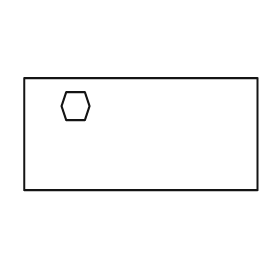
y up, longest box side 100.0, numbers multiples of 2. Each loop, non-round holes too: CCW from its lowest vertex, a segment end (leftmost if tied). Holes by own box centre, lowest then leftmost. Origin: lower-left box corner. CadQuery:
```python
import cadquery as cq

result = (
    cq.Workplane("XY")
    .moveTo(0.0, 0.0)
    .lineTo(100.0, 0.0)
    .lineTo(100.0, 48.0)
    .lineTo(0.0, 48.0)
    .close()
    .moveTo(18.0, 30.0)
    .lineTo(26.0, 30.0)
    .lineTo(28.0, 36.0)
    .lineTo(26.0, 42.0)
    .lineTo(18.0, 42.0)
    .lineTo(16.0, 36.0)
    .close()
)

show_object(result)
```